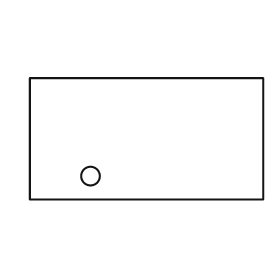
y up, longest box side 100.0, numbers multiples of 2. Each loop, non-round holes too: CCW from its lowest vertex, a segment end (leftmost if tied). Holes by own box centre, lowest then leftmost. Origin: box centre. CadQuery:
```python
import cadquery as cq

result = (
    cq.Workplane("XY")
    .moveTo(-50.0, -26.0)
    .lineTo(50.0, -26.0)
    .lineTo(50.0, 26.0)
    .lineTo(-50.0, 26.0)
    .close()
    .moveTo(-24.0, -16.0)
    .circle(4.0)
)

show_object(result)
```